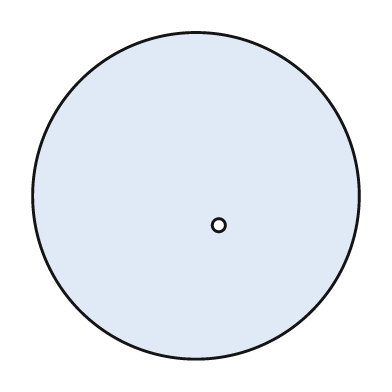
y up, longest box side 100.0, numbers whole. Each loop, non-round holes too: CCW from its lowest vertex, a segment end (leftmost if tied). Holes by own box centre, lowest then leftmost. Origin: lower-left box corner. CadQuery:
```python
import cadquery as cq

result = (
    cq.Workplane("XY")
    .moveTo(50.0, 50.0)
    .circle(50.0)
    .moveTo(57.0, 41.0)
    .circle(2.0)
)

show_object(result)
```